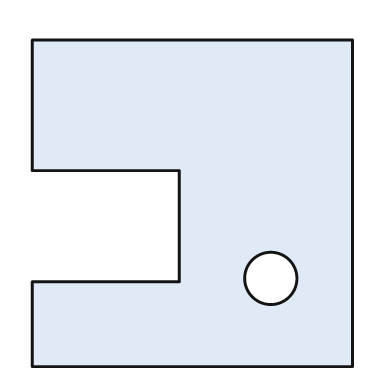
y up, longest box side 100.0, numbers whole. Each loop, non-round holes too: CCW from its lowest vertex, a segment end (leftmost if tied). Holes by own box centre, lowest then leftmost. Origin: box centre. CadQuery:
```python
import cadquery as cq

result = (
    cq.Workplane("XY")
    .moveTo(-49.0, -50.0)
    .lineTo(49.0, -50.0)
    .lineTo(49.0, 50.0)
    .lineTo(-49.0, 50.0)
    .lineTo(-49.0, 10.0)
    .lineTo(-4.0, 10.0)
    .lineTo(-4.0, -24.0)
    .lineTo(-49.0, -24.0)
    .close()
    .moveTo(24.0, -23.0)
    .circle(8.0)
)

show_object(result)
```